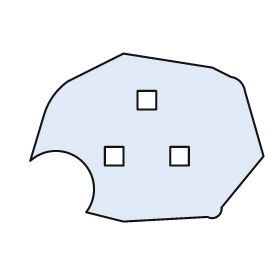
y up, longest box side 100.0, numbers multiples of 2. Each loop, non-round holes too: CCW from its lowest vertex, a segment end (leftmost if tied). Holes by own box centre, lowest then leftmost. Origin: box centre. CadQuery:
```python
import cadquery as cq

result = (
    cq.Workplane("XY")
    .moveTo(-10.0, -36.0)
    .lineTo(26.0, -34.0)
    .threePointArc((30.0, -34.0), (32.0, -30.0))
    .lineTo(50.0, -8.0)
    .lineTo(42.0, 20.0)
    .threePointArc((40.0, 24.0), (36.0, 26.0))
    .lineTo(28.0, 30.0)
    .lineTo(-10.0, 36.0)
    .lineTo(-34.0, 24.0)
    .threePointArc((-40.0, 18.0), (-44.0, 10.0))
    .lineTo(-50.0, -10.0)
    .threePointArc((-28.0, -10.0), (-26.0, -32.0))
    .close()
    .moveTo(-18.0, -12.0)
    .lineTo(-10.0, -12.0)
    .lineTo(-10.0, -4.0)
    .lineTo(-18.0, -4.0)
    .close()
    .moveTo(10.0, -12.0)
    .lineTo(18.0, -12.0)
    .lineTo(18.0, -4.0)
    .lineTo(10.0, -4.0)
    .close()
    .moveTo(-4.0, 12.0)
    .lineTo(4.0, 12.0)
    .lineTo(4.0, 20.0)
    .lineTo(-4.0, 20.0)
    .close()
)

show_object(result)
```